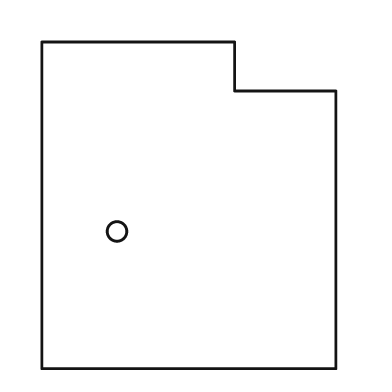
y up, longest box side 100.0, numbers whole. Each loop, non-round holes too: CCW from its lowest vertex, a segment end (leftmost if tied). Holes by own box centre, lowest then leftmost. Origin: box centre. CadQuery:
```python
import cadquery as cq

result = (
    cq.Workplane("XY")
    .moveTo(-45.0, -50.0)
    .lineTo(45.0, -50.0)
    .lineTo(45.0, 35.0)
    .lineTo(14.0, 35.0)
    .lineTo(14.0, 50.0)
    .lineTo(-45.0, 50.0)
    .close()
    .moveTo(-22.0, -8.0)
    .circle(3.0)
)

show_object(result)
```